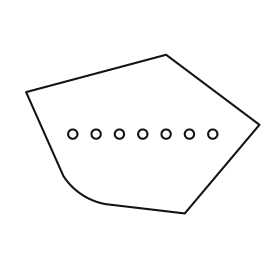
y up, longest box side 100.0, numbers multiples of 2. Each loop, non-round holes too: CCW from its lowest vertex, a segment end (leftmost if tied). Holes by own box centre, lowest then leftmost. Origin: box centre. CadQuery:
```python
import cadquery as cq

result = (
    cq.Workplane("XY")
    .moveTo(18.0, -34.0)
    .lineTo(50.0, 4.0)
    .lineTo(10.0, 34.0)
    .lineTo(-50.0, 18.0)
    .lineTo(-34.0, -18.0)
    .threePointArc((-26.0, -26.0), (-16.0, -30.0))
    .close()
    .moveTo(-30.0, 0.0)
    .circle(2.0)
    .moveTo(-20.0, 0.0)
    .circle(2.0)
    .moveTo(-10.0, 0.0)
    .circle(2.0)
    .moveTo(0.0, 0.0)
    .circle(2.0)
    .moveTo(10.0, 0.0)
    .circle(2.0)
    .moveTo(20.0, 0.0)
    .circle(2.0)
    .moveTo(30.0, 0.0)
    .circle(2.0)
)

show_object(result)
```